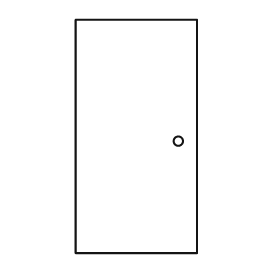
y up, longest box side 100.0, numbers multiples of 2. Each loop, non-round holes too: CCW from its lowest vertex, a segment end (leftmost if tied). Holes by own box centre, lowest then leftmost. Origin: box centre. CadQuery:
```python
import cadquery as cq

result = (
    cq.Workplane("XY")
    .moveTo(-26.0, -50.0)
    .lineTo(26.0, -50.0)
    .lineTo(26.0, 50.0)
    .lineTo(-26.0, 50.0)
    .close()
    .moveTo(18.0, -2.0)
    .circle(2.0)
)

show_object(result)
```